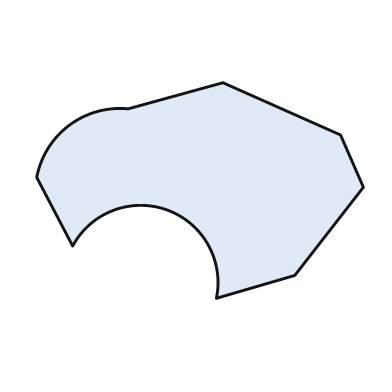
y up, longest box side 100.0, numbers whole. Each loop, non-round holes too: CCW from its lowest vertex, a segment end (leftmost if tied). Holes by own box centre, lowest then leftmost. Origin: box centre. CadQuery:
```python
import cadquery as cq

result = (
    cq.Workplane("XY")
    .moveTo(5.0, -33.0)
    .lineTo(29.0, -26.0)
    .lineTo(50.0, 1.0)
    .lineTo(43.0, 17.0)
    .lineTo(7.0, 33.0)
    .lineTo(-22.0, 25.0)
    .threePointArc((-40.0, 20.0), (-50.0, 4.0))
    .lineTo(-39.0, -17.0)
    .threePointArc((-10.0, -6.0), (5.0, -33.0))
    .close()
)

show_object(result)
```